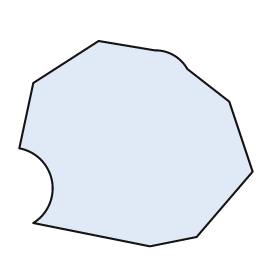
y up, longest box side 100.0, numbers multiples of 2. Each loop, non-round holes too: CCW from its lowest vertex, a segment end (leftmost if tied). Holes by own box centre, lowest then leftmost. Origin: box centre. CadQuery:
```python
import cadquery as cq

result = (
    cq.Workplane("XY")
    .moveTo(6.0, -44.0)
    .lineTo(26.0, -40.0)
    .lineTo(50.0, -12.0)
    .lineTo(40.0, 18.0)
    .lineTo(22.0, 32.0)
    .threePointArc((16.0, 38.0), (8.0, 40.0))
    .lineTo(-16.0, 44.0)
    .lineTo(-44.0, 26.0)
    .lineTo(-50.0, -2.0)
    .threePointArc((-36.0, -16.0), (-44.0, -34.0))
    .close()
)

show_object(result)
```